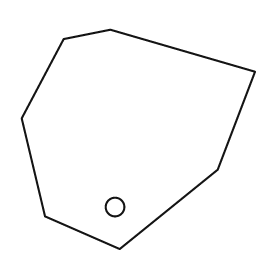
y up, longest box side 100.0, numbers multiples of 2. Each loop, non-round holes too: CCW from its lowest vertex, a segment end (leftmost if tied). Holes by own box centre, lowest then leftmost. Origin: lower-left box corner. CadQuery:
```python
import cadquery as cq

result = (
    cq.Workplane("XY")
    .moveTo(42.0, 0.0)
    .lineTo(84.0, 34.0)
    .lineTo(100.0, 76.0)
    .lineTo(38.0, 94.0)
    .lineTo(18.0, 90.0)
    .lineTo(0.0, 56.0)
    .lineTo(10.0, 14.0)
    .close()
    .moveTo(40.0, 18.0)
    .circle(4.0)
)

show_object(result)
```